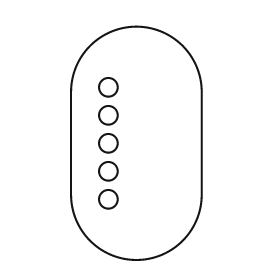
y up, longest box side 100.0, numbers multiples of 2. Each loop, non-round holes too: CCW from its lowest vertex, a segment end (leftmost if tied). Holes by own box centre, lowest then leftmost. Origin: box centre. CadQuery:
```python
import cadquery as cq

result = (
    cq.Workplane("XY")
    .moveTo(-28.0, -22.0)
    .threePointArc((0.0, -50.0), (28.0, -22.0))
    .lineTo(28.0, 22.0)
    .threePointArc((0.0, 50.0), (-28.0, 22.0))
    .close()
    .moveTo(-12.0, -24.0)
    .circle(4.0)
    .moveTo(-12.0, -12.0)
    .circle(4.0)
    .moveTo(-12.0, 0.0)
    .circle(4.0)
    .moveTo(-12.0, 12.0)
    .circle(4.0)
    .moveTo(-12.0, 24.0)
    .circle(4.0)
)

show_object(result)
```